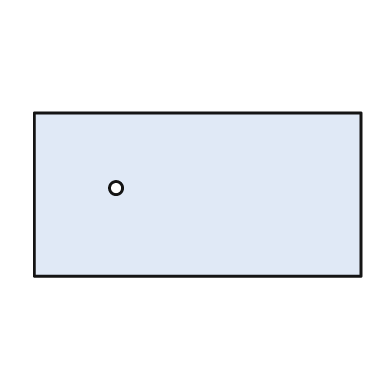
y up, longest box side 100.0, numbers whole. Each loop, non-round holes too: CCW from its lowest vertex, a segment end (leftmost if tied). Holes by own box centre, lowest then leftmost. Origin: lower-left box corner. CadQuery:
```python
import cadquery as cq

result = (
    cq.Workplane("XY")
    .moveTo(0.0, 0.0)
    .lineTo(100.0, 0.0)
    .lineTo(100.0, 50.0)
    .lineTo(0.0, 50.0)
    .close()
    .moveTo(25.0, 27.0)
    .circle(2.0)
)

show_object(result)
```